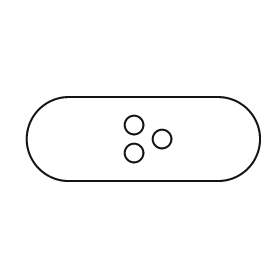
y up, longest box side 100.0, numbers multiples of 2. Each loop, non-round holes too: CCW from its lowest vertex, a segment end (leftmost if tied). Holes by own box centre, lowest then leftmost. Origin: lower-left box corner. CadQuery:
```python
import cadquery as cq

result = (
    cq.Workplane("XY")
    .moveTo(18.0, 0.0)
    .lineTo(82.0, 0.0)
    .threePointArc((100.0, 18.0), (82.0, 36.0))
    .lineTo(18.0, 36.0)
    .threePointArc((0.0, 18.0), (18.0, 0.0))
    .close()
    .moveTo(46.0, 12.0)
    .circle(4.0)
    .moveTo(58.0, 18.0)
    .circle(4.0)
    .moveTo(46.0, 24.0)
    .circle(4.0)
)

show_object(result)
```